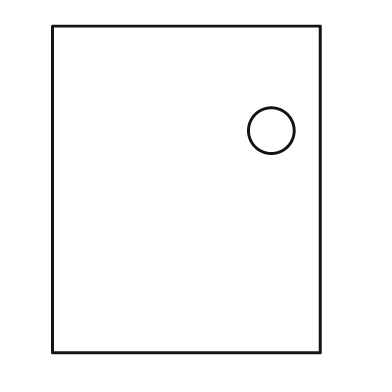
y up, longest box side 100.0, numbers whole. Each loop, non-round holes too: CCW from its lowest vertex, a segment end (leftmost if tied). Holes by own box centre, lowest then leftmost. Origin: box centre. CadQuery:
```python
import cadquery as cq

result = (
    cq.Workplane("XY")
    .moveTo(-41.0, -50.0)
    .lineTo(41.0, -50.0)
    .lineTo(41.0, 50.0)
    .lineTo(-41.0, 50.0)
    .close()
    .moveTo(26.0, 18.0)
    .circle(7.0)
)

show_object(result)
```